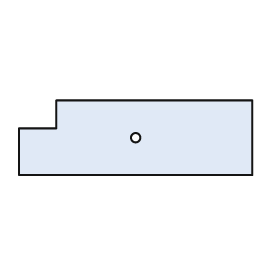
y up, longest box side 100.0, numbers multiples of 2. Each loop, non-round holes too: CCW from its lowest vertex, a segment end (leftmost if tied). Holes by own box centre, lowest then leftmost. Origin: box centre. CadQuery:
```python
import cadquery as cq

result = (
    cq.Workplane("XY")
    .moveTo(-50.0, -16.0)
    .lineTo(50.0, -16.0)
    .lineTo(50.0, 16.0)
    .lineTo(-34.0, 16.0)
    .lineTo(-34.0, 4.0)
    .lineTo(-50.0, 4.0)
    .close()
    .moveTo(0.0, 0.0)
    .circle(2.0)
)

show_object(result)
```